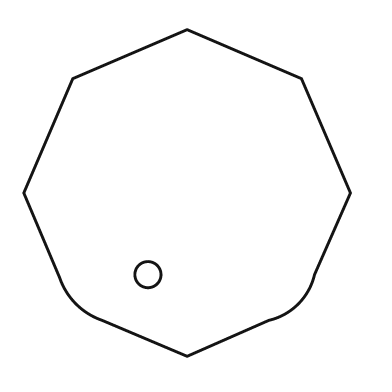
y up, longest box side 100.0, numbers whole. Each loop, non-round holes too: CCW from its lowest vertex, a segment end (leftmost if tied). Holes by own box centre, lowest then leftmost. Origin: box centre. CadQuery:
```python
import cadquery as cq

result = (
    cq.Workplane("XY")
    .moveTo(0.0, -50.0)
    .lineTo(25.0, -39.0)
    .threePointArc((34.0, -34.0), (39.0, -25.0))
    .lineTo(50.0, 0.0)
    .lineTo(35.0, 35.0)
    .lineTo(0.0, 50.0)
    .lineTo(-35.0, 35.0)
    .lineTo(-50.0, 0.0)
    .lineTo(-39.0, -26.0)
    .threePointArc((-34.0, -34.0), (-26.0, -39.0))
    .close()
    .moveTo(-12.0, -25.0)
    .circle(4.0)
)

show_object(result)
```